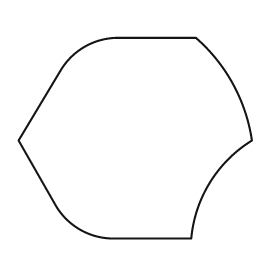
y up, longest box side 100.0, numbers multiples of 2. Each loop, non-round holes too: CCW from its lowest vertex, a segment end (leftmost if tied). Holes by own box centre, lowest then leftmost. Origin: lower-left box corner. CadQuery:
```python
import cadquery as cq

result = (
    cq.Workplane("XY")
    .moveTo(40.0, 0.0)
    .lineTo(74.0, 0.0)
    .threePointArc((82.0, 24.0), (100.0, 42.0))
    .threePointArc((92.0, 66.0), (76.0, 86.0))
    .lineTo(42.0, 86.0)
    .threePointArc((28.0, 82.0), (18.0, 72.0))
    .lineTo(0.0, 42.0)
    .lineTo(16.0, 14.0)
    .threePointArc((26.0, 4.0), (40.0, 0.0))
    .close()
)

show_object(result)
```